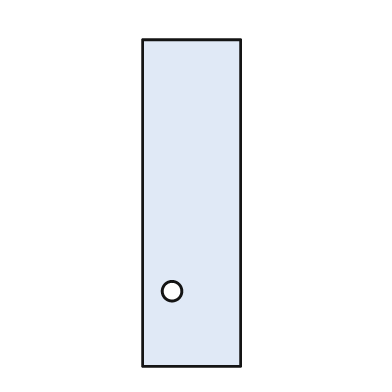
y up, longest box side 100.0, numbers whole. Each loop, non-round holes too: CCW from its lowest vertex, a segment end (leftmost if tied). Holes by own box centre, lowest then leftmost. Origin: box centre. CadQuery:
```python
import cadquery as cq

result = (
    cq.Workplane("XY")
    .moveTo(-15.0, -50.0)
    .lineTo(15.0, -50.0)
    .lineTo(15.0, 50.0)
    .lineTo(-15.0, 50.0)
    .close()
    .moveTo(-6.0, -27.0)
    .circle(3.0)
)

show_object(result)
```